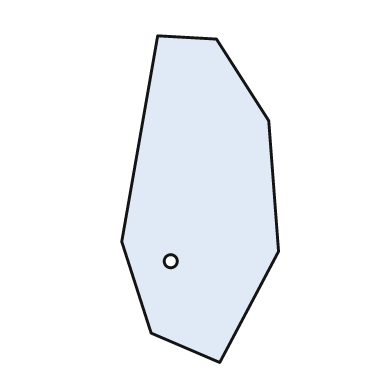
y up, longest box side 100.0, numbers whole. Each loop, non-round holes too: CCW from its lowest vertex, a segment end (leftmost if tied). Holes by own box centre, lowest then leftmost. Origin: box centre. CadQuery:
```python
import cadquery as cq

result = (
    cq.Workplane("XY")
    .moveTo(6.0, -50.0)
    .lineTo(24.0, -16.0)
    .lineTo(21.0, 24.0)
    .lineTo(5.0, 49.0)
    .lineTo(-13.0, 50.0)
    .lineTo(-24.0, -13.0)
    .lineTo(-15.0, -41.0)
    .close()
    .moveTo(-9.0, -19.0)
    .circle(2.0)
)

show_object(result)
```